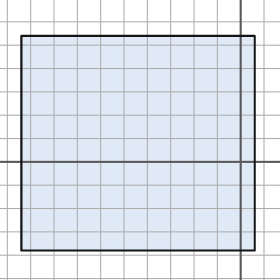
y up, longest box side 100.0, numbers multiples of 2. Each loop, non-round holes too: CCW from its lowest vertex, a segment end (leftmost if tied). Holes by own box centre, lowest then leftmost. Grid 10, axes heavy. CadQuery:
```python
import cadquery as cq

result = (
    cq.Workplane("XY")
    .moveTo(-94.0, -38.0)
    .lineTo(6.0, -38.0)
    .lineTo(6.0, 54.0)
    .lineTo(-94.0, 54.0)
    .close()
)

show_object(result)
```